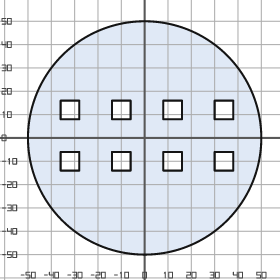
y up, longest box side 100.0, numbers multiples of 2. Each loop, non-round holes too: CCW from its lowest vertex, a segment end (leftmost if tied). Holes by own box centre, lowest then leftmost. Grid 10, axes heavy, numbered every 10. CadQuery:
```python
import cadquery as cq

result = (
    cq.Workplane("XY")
    .moveTo(0.0, 0.0)
    .circle(50.0)
    .moveTo(-36.0, -14.0)
    .lineTo(-28.0, -14.0)
    .lineTo(-28.0, -6.0)
    .lineTo(-36.0, -6.0)
    .close()
    .moveTo(-14.0, -14.0)
    .lineTo(-6.0, -14.0)
    .lineTo(-6.0, -6.0)
    .lineTo(-14.0, -6.0)
    .close()
    .moveTo(8.0, -14.0)
    .lineTo(16.0, -14.0)
    .lineTo(16.0, -6.0)
    .lineTo(8.0, -6.0)
    .close()
    .moveTo(30.0, -14.0)
    .lineTo(38.0, -14.0)
    .lineTo(38.0, -6.0)
    .lineTo(30.0, -6.0)
    .close()
    .moveTo(-36.0, 8.0)
    .lineTo(-28.0, 8.0)
    .lineTo(-28.0, 16.0)
    .lineTo(-36.0, 16.0)
    .close()
    .moveTo(-14.0, 8.0)
    .lineTo(-6.0, 8.0)
    .lineTo(-6.0, 16.0)
    .lineTo(-14.0, 16.0)
    .close()
    .moveTo(8.0, 8.0)
    .lineTo(16.0, 8.0)
    .lineTo(16.0, 16.0)
    .lineTo(8.0, 16.0)
    .close()
    .moveTo(30.0, 8.0)
    .lineTo(38.0, 8.0)
    .lineTo(38.0, 16.0)
    .lineTo(30.0, 16.0)
    .close()
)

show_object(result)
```